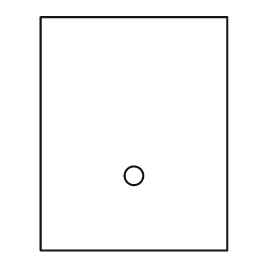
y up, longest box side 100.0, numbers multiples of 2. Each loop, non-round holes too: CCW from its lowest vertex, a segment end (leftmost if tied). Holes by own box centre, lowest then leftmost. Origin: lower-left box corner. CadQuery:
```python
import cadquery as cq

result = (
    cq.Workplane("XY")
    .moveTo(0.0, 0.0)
    .lineTo(80.0, 0.0)
    .lineTo(80.0, 100.0)
    .lineTo(0.0, 100.0)
    .close()
    .moveTo(40.0, 32.0)
    .circle(4.0)
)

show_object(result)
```